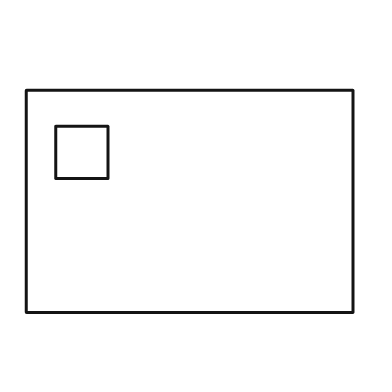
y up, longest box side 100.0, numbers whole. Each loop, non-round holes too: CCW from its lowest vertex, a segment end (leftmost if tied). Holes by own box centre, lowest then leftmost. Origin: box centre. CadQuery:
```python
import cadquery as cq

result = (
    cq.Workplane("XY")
    .moveTo(-50.0, -34.0)
    .lineTo(50.0, -34.0)
    .lineTo(50.0, 34.0)
    .lineTo(-50.0, 34.0)
    .close()
    .moveTo(-41.0, 7.0)
    .lineTo(-25.0, 7.0)
    .lineTo(-25.0, 23.0)
    .lineTo(-41.0, 23.0)
    .close()
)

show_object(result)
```